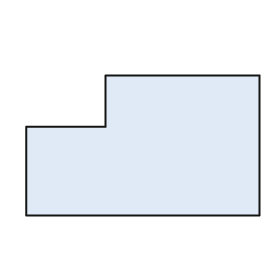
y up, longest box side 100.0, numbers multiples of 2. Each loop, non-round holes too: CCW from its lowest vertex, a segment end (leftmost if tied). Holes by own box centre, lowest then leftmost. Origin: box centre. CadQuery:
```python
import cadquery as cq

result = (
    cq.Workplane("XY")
    .moveTo(-50.0, -30.0)
    .lineTo(50.0, -30.0)
    .lineTo(50.0, 30.0)
    .lineTo(-16.0, 30.0)
    .lineTo(-16.0, 8.0)
    .lineTo(-50.0, 8.0)
    .close()
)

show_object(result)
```